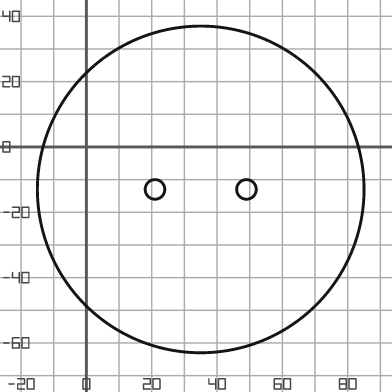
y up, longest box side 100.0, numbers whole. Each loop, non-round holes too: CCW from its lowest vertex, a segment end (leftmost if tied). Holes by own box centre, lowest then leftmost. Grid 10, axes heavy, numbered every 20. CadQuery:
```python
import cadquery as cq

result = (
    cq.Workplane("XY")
    .moveTo(35.0, -13.0)
    .circle(50.0)
    .moveTo(21.0, -13.0)
    .circle(3.0)
    .moveTo(49.0, -13.0)
    .circle(3.0)
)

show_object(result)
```